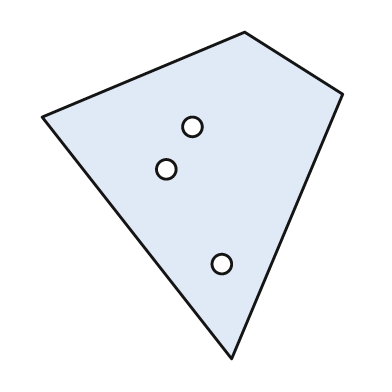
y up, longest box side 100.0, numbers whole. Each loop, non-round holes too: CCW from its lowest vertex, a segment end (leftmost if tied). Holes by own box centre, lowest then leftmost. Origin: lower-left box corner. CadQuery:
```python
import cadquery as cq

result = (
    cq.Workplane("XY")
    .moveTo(58.0, 0.0)
    .lineTo(92.0, 81.0)
    .lineTo(62.0, 100.0)
    .lineTo(0.0, 74.0)
    .close()
    .moveTo(55.0, 29.0)
    .circle(3.0)
    .moveTo(38.0, 58.0)
    .circle(3.0)
    .moveTo(46.0, 71.0)
    .circle(3.0)
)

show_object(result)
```